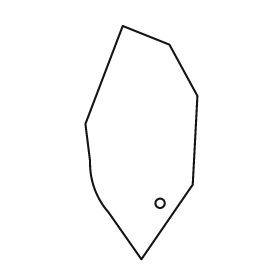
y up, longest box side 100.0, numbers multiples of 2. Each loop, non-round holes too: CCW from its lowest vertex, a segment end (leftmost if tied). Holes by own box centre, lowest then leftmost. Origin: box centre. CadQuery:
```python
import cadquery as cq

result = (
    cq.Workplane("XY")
    .moveTo(0.0, -50.0)
    .lineTo(22.0, -18.0)
    .lineTo(24.0, 20.0)
    .lineTo(12.0, 42.0)
    .lineTo(-8.0, 50.0)
    .lineTo(-24.0, 8.0)
    .lineTo(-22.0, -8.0)
    .threePointArc((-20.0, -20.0), (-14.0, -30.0))
    .close()
    .moveTo(8.0, -26.0)
    .circle(2.0)
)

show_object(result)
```